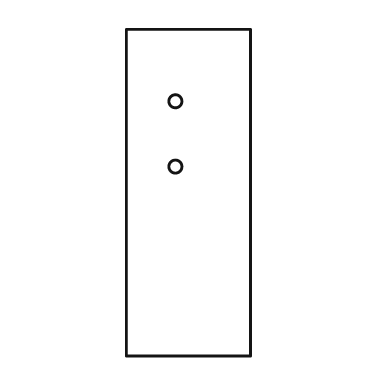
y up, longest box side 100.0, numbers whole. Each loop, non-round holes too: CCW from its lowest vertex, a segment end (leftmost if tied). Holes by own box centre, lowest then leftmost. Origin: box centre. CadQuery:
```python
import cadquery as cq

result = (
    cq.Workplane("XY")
    .moveTo(-19.0, -50.0)
    .lineTo(19.0, -50.0)
    .lineTo(19.0, 50.0)
    .lineTo(-19.0, 50.0)
    .close()
    .moveTo(-4.0, 8.0)
    .circle(2.0)
    .moveTo(-4.0, 28.0)
    .circle(2.0)
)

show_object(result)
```